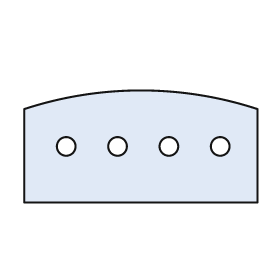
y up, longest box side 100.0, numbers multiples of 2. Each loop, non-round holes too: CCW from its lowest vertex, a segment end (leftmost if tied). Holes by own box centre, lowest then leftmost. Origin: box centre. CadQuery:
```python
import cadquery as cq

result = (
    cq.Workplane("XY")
    .moveTo(-50.0, -24.0)
    .lineTo(50.0, -24.0)
    .lineTo(50.0, 16.0)
    .threePointArc((0.0, 24.0), (-50.0, 16.0))
    .close()
    .moveTo(-32.0, 0.0)
    .circle(4.0)
    .moveTo(-10.0, 0.0)
    .circle(4.0)
    .moveTo(12.0, 0.0)
    .circle(4.0)
    .moveTo(34.0, 0.0)
    .circle(4.0)
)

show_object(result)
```